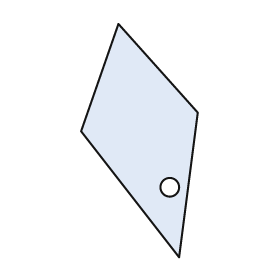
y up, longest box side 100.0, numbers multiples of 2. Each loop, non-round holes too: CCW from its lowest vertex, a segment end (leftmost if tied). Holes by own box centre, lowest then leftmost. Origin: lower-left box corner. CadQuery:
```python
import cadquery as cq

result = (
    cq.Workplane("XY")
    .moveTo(42.0, 0.0)
    .lineTo(50.0, 62.0)
    .lineTo(16.0, 100.0)
    .lineTo(0.0, 54.0)
    .close()
    .moveTo(38.0, 30.0)
    .circle(4.0)
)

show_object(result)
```